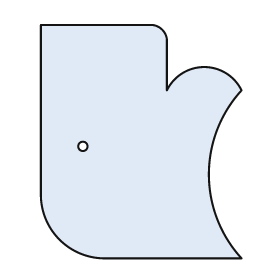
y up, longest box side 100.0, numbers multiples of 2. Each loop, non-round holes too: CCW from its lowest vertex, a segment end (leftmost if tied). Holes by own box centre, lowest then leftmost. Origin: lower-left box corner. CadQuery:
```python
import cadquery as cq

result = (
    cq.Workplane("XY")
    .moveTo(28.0, 0.0)
    .lineTo(86.0, 0.0)
    .threePointArc((72.0, 36.0), (86.0, 72.0))
    .threePointArc((70.0, 82.0), (54.0, 72.0))
    .lineTo(54.0, 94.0)
    .threePointArc((52.0, 98.0), (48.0, 100.0))
    .lineTo(0.0, 100.0)
    .lineTo(0.0, 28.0)
    .threePointArc((8.0, 8.0), (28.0, 0.0))
    .close()
    .moveTo(18.0, 48.0)
    .circle(2.0)
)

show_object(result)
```